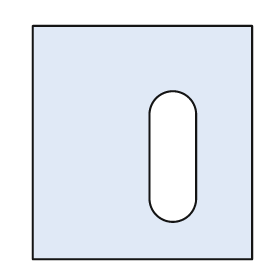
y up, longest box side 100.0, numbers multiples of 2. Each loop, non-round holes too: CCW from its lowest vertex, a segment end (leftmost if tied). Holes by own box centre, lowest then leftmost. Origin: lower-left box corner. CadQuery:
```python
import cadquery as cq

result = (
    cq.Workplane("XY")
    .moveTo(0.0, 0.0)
    .lineTo(94.0, 0.0)
    .lineTo(94.0, 100.0)
    .lineTo(0.0, 100.0)
    .close()
    .moveTo(50.0, 26.0)
    .threePointArc((60.0, 16.0), (70.0, 26.0))
    .lineTo(70.0, 62.0)
    .threePointArc((60.0, 72.0), (50.0, 62.0))
    .close()
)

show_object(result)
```